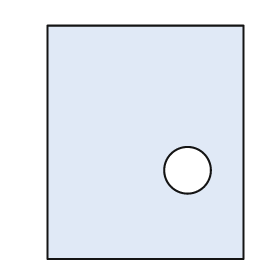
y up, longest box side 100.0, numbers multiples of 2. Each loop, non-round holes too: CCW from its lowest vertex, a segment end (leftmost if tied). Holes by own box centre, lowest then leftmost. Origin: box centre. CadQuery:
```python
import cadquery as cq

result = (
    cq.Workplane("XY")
    .moveTo(-42.0, -50.0)
    .lineTo(42.0, -50.0)
    .lineTo(42.0, 50.0)
    .lineTo(-42.0, 50.0)
    .close()
    .moveTo(18.0, -12.0)
    .circle(10.0)
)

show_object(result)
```